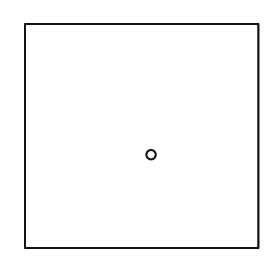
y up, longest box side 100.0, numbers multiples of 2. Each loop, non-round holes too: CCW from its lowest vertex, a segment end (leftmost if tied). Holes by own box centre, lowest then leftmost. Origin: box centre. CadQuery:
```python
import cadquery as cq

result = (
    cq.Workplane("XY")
    .moveTo(-50.0, -48.0)
    .lineTo(50.0, -48.0)
    .lineTo(50.0, 48.0)
    .lineTo(-50.0, 48.0)
    .close()
    .moveTo(4.0, -8.0)
    .circle(2.0)
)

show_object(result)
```